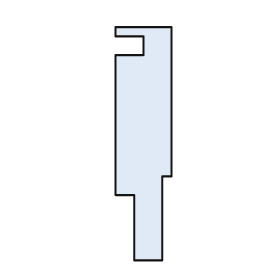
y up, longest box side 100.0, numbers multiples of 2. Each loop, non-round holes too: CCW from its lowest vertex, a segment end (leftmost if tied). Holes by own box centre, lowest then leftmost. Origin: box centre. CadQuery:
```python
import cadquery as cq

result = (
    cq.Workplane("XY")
    .moveTo(-4.0, -50.0)
    .lineTo(8.0, -50.0)
    .lineTo(8.0, -14.0)
    .lineTo(12.0, -14.0)
    .lineTo(12.0, 50.0)
    .lineTo(-12.0, 50.0)
    .lineTo(-12.0, 46.0)
    .lineTo(0.0, 46.0)
    .lineTo(0.0, 38.0)
    .lineTo(-12.0, 38.0)
    .lineTo(-12.0, -22.0)
    .lineTo(-4.0, -22.0)
    .close()
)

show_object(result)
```